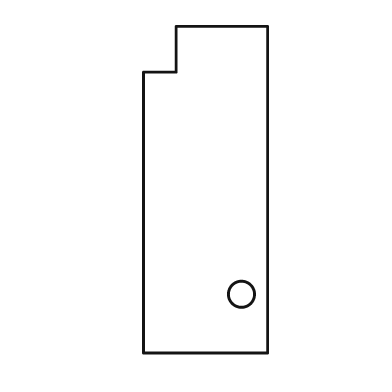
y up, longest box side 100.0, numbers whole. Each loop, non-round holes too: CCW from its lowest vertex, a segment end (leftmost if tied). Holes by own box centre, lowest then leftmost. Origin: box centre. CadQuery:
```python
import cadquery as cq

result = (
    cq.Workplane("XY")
    .moveTo(-19.0, -50.0)
    .lineTo(19.0, -50.0)
    .lineTo(19.0, 50.0)
    .lineTo(-9.0, 50.0)
    .lineTo(-9.0, 36.0)
    .lineTo(-19.0, 36.0)
    .close()
    .moveTo(11.0, -32.0)
    .circle(4.0)
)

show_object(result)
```